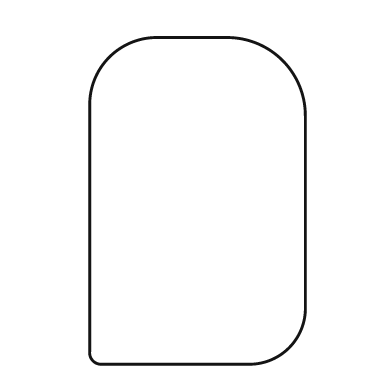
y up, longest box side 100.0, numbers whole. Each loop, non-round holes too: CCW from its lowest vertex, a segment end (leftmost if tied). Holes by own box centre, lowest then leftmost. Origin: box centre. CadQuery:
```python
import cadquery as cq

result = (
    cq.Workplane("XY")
    .moveTo(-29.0, -50.0)
    .lineTo(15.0, -50.0)
    .threePointArc((28.0, -45.0), (33.0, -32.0))
    .lineTo(33.0, 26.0)
    .threePointArc((26.0, 43.0), (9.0, 50.0))
    .lineTo(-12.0, 50.0)
    .threePointArc((-27.0, 44.0), (-33.0, 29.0))
    .lineTo(-33.0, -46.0)
    .threePointArc((-32.0, -49.0), (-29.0, -50.0))
    .close()
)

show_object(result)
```